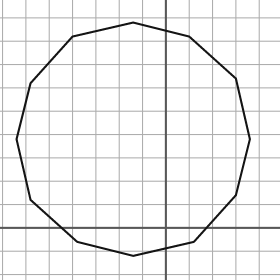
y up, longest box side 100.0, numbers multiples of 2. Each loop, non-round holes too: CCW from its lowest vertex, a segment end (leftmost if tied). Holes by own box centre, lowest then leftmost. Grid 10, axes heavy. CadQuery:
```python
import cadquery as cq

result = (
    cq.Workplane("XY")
    .moveTo(-14.0, -12.0)
    .lineTo(12.0, -6.0)
    .lineTo(30.0, 14.0)
    .lineTo(36.0, 38.0)
    .lineTo(30.0, 64.0)
    .lineTo(10.0, 82.0)
    .lineTo(-14.0, 88.0)
    .lineTo(-40.0, 82.0)
    .lineTo(-58.0, 62.0)
    .lineTo(-64.0, 38.0)
    .lineTo(-58.0, 12.0)
    .lineTo(-38.0, -6.0)
    .close()
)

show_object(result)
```